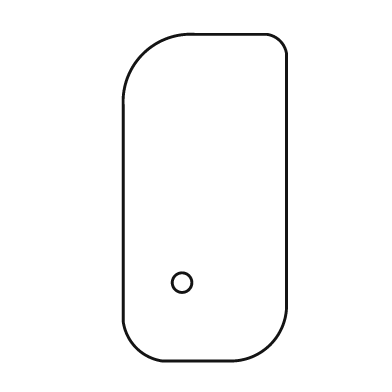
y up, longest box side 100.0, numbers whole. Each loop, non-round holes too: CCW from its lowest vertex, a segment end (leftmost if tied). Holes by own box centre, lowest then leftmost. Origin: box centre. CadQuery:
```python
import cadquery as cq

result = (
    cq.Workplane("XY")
    .moveTo(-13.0, -50.0)
    .lineTo(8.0, -50.0)
    .threePointArc((20.0, -45.0), (25.0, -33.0))
    .lineTo(25.0, 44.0)
    .threePointArc((23.0, 48.0), (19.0, 50.0))
    .lineTo(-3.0, 50.0)
    .threePointArc((-19.0, 44.0), (-25.0, 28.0))
    .lineTo(-25.0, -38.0)
    .threePointArc((-21.0, -46.0), (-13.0, -50.0))
    .close()
    .moveTo(-7.0, -26.0)
    .circle(3.0)
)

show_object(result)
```